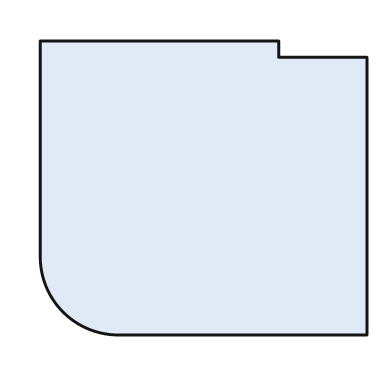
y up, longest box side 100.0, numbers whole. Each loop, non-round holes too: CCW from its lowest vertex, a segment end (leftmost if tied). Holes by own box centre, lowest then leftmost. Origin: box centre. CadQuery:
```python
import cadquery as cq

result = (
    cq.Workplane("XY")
    .moveTo(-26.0, -45.0)
    .lineTo(50.0, -45.0)
    .lineTo(50.0, 40.0)
    .lineTo(23.0, 40.0)
    .lineTo(23.0, 45.0)
    .lineTo(-50.0, 45.0)
    .lineTo(-50.0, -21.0)
    .threePointArc((-43.0, -38.0), (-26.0, -45.0))
    .close()
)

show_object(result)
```